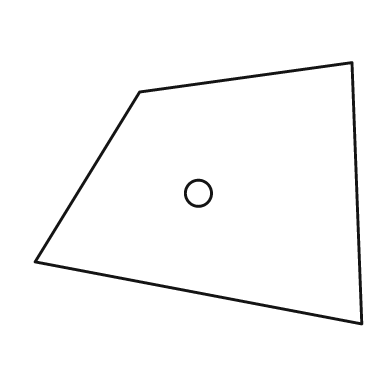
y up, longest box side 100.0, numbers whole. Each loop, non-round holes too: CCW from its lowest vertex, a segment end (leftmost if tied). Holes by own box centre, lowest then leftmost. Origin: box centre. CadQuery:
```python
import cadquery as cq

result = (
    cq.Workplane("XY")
    .moveTo(50.0, -40.0)
    .lineTo(47.0, 40.0)
    .lineTo(-18.0, 31.0)
    .lineTo(-50.0, -21.0)
    .close()
    .moveTo(0.0, 0.0)
    .circle(4.0)
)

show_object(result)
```